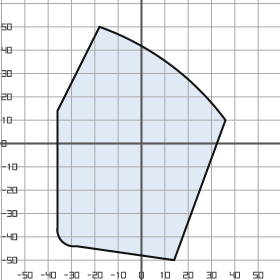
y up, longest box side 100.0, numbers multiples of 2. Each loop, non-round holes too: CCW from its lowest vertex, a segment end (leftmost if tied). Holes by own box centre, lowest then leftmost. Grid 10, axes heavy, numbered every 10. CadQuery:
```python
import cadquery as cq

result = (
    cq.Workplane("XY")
    .moveTo(14.0, -50.0)
    .lineTo(36.0, 10.0)
    .threePointArc((12.0, 34.0), (-18.0, 50.0))
    .lineTo(-36.0, 14.0)
    .lineTo(-36.0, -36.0)
    .threePointArc((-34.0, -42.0), (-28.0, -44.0))
    .close()
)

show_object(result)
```